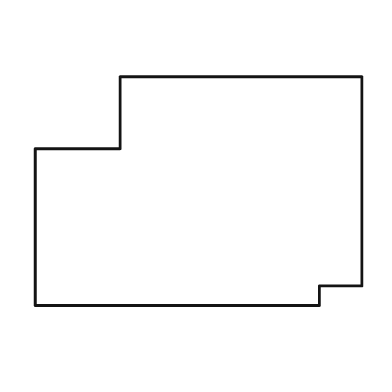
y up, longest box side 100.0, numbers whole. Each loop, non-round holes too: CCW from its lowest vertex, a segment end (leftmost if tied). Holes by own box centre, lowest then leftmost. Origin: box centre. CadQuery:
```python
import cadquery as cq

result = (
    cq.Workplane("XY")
    .moveTo(-50.0, -35.0)
    .lineTo(37.0, -35.0)
    .lineTo(37.0, -29.0)
    .lineTo(50.0, -29.0)
    .lineTo(50.0, 35.0)
    .lineTo(-24.0, 35.0)
    .lineTo(-24.0, 13.0)
    .lineTo(-50.0, 13.0)
    .close()
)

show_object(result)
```